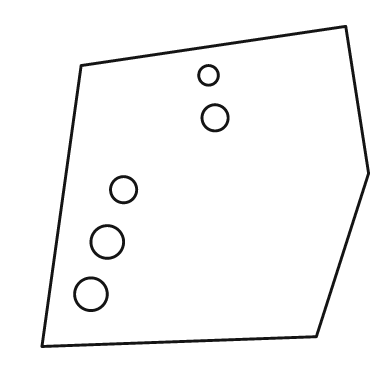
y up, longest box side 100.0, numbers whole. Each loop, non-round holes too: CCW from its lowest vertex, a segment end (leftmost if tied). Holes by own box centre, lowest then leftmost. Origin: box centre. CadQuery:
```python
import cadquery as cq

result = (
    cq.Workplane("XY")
    .moveTo(-50.0, -49.0)
    .lineTo(34.0, -46.0)
    .lineTo(50.0, 4.0)
    .lineTo(43.0, 49.0)
    .lineTo(-38.0, 37.0)
    .close()
    .moveTo(-35.0, -33.0)
    .circle(5.0)
    .moveTo(-30.0, -17.0)
    .circle(5.0)
    .moveTo(-25.0, -1.0)
    .circle(4.0)
    .moveTo(3.0, 21.0)
    .circle(4.0)
    .moveTo(1.0, 34.0)
    .circle(3.0)
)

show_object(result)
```